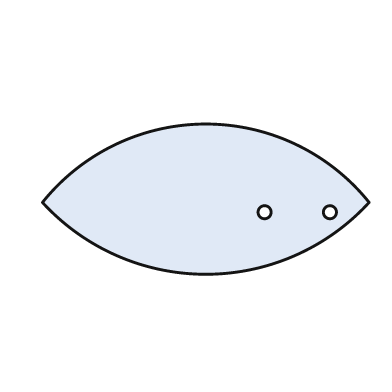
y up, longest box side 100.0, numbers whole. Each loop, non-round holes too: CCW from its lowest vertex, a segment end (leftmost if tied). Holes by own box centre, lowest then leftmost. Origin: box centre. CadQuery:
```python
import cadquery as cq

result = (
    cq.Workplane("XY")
    .moveTo(-50.0, -1.0)
    .threePointArc((0.0, -23.0), (50.0, -1.0))
    .threePointArc((0.0, 23.0), (-50.0, -1.0))
    .close()
    .moveTo(18.0, -4.0)
    .circle(2.0)
    .moveTo(38.0, -4.0)
    .circle(2.0)
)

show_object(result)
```